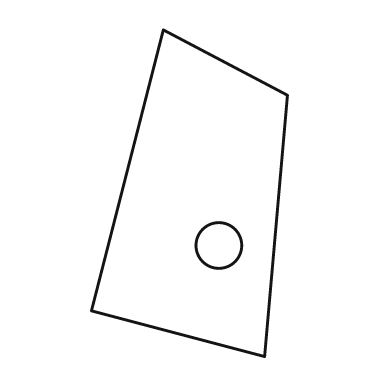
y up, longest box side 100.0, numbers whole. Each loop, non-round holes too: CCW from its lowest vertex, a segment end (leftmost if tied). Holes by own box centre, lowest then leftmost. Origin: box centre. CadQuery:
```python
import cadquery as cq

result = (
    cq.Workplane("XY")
    .moveTo(23.0, -50.0)
    .lineTo(30.0, 30.0)
    .lineTo(-8.0, 50.0)
    .lineTo(-30.0, -36.0)
    .close()
    .moveTo(9.0, -16.0)
    .circle(7.0)
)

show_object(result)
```